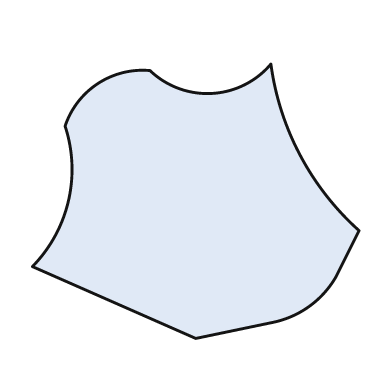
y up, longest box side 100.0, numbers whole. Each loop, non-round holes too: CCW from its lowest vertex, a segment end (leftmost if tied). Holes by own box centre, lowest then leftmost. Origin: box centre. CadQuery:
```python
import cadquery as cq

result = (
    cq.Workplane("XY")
    .moveTo(0.0, -42.0)
    .lineTo(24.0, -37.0)
    .threePointArc((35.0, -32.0), (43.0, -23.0))
    .lineTo(50.0, -9.0)
    .threePointArc((32.0, 14.0), (23.0, 42.0))
    .threePointArc((5.0, 33.0), (-14.0, 40.0))
    .threePointArc((-30.0, 36.0), (-40.0, 23.0))
    .threePointArc((-39.0, 0.0), (-50.0, -20.0))
    .close()
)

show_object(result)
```